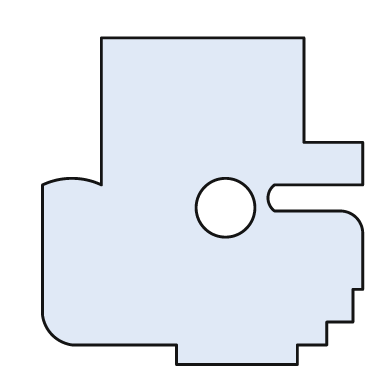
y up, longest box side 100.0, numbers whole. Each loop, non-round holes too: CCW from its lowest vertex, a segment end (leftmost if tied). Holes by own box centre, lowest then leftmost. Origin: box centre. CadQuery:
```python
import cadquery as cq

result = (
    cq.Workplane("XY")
    .moveTo(-8.0, -50.0)
    .lineTo(29.0, -50.0)
    .lineTo(29.0, -44.0)
    .lineTo(38.0, -44.0)
    .lineTo(38.0, -37.0)
    .lineTo(46.0, -37.0)
    .lineTo(46.0, -27.0)
    .lineTo(49.0, -27.0)
    .lineTo(49.0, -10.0)
    .threePointArc((47.0, -5.0), (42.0, -3.0))
    .lineTo(22.0, -3.0)
    .threePointArc((20.0, 1.0), (22.0, 5.0))
    .lineTo(49.0, 5.0)
    .lineTo(49.0, 18.0)
    .lineTo(31.0, 18.0)
    .lineTo(31.0, 50.0)
    .lineTo(-31.0, 50.0)
    .lineTo(-31.0, 5.0)
    .threePointArc((-40.0, 7.0), (-49.0, 5.0))
    .lineTo(-49.0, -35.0)
    .threePointArc((-46.0, -41.0), (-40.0, -44.0))
    .lineTo(-8.0, -44.0)
    .close()
    .moveTo(7.0, -2.0)
    .circle(9.0)
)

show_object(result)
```